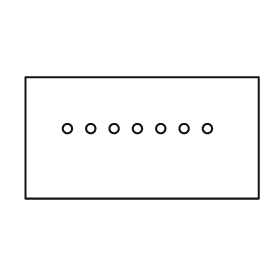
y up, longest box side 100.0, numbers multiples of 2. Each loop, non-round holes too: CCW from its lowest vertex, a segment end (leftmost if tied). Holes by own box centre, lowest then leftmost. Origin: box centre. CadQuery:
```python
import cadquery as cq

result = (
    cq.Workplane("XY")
    .moveTo(-50.0, -26.0)
    .lineTo(50.0, -26.0)
    .lineTo(50.0, 26.0)
    .lineTo(-50.0, 26.0)
    .close()
    .moveTo(-32.0, 4.0)
    .circle(2.0)
    .moveTo(-22.0, 4.0)
    .circle(2.0)
    .moveTo(-12.0, 4.0)
    .circle(2.0)
    .moveTo(-2.0, 4.0)
    .circle(2.0)
    .moveTo(8.0, 4.0)
    .circle(2.0)
    .moveTo(18.0, 4.0)
    .circle(2.0)
    .moveTo(28.0, 4.0)
    .circle(2.0)
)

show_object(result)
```